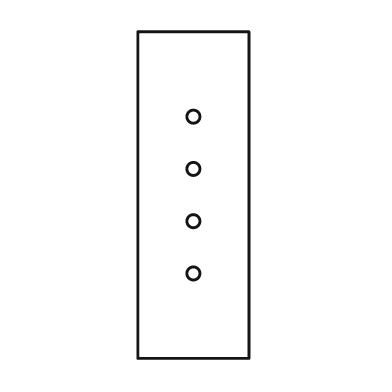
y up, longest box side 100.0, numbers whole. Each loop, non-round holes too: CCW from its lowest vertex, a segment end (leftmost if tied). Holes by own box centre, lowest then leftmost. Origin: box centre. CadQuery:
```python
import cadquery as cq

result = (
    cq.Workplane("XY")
    .moveTo(-17.0, -50.0)
    .lineTo(17.0, -50.0)
    .lineTo(17.0, 50.0)
    .lineTo(-17.0, 50.0)
    .close()
    .moveTo(0.0, -24.0)
    .circle(2.0)
    .moveTo(0.0, -8.0)
    .circle(2.0)
    .moveTo(0.0, 8.0)
    .circle(2.0)
    .moveTo(0.0, 24.0)
    .circle(2.0)
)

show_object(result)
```